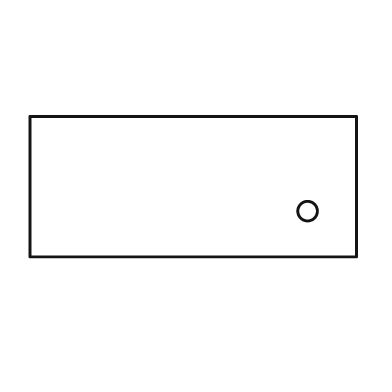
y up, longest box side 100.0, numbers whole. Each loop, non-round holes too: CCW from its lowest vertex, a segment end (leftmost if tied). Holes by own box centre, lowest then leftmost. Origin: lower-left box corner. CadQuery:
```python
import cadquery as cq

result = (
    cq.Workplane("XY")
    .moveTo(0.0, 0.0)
    .lineTo(100.0, 0.0)
    .lineTo(100.0, 43.0)
    .lineTo(0.0, 43.0)
    .close()
    .moveTo(85.0, 14.0)
    .circle(3.0)
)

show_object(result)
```